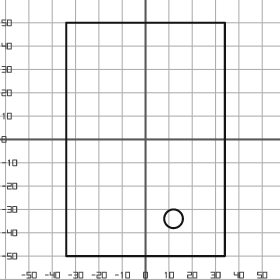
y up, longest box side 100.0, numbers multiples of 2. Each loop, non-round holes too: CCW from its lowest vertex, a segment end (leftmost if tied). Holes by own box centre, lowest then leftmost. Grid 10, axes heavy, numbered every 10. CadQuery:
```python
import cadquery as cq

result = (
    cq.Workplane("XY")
    .moveTo(-34.0, -50.0)
    .lineTo(34.0, -50.0)
    .lineTo(34.0, 50.0)
    .lineTo(-34.0, 50.0)
    .close()
    .moveTo(12.0, -34.0)
    .circle(4.0)
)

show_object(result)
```